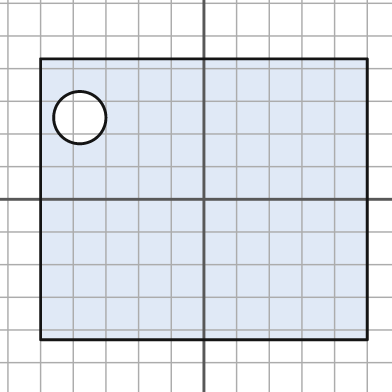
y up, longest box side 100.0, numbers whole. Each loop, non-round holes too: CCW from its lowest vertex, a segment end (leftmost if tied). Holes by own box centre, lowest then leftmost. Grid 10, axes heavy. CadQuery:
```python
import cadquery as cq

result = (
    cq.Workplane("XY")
    .moveTo(-50.0, -43.0)
    .lineTo(50.0, -43.0)
    .lineTo(50.0, 43.0)
    .lineTo(-50.0, 43.0)
    .close()
    .moveTo(-38.0, 25.0)
    .circle(8.0)
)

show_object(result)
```